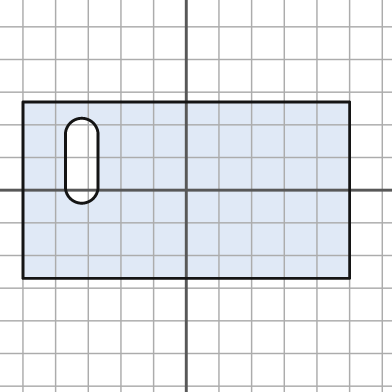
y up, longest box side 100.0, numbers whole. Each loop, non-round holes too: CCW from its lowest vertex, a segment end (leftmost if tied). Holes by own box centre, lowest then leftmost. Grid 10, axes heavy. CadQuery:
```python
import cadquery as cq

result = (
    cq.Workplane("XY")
    .moveTo(-50.0, -27.0)
    .lineTo(50.0, -27.0)
    .lineTo(50.0, 27.0)
    .lineTo(-50.0, 27.0)
    .close()
    .moveTo(-37.0, 1.0)
    .threePointArc((-32.0, -4.0), (-27.0, 1.0))
    .lineTo(-27.0, 17.0)
    .threePointArc((-32.0, 22.0), (-37.0, 17.0))
    .close()
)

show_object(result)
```